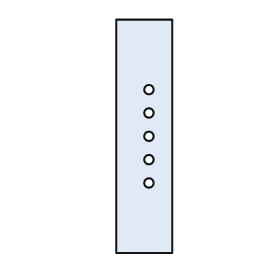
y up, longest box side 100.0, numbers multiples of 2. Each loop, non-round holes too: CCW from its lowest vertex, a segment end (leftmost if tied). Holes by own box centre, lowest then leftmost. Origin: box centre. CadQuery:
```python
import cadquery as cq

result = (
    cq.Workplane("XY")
    .moveTo(-12.0, -50.0)
    .lineTo(12.0, -50.0)
    .lineTo(12.0, 50.0)
    .lineTo(-12.0, 50.0)
    .close()
    .moveTo(2.0, -20.0)
    .circle(2.0)
    .moveTo(2.0, -10.0)
    .circle(2.0)
    .moveTo(2.0, 0.0)
    .circle(2.0)
    .moveTo(2.0, 10.0)
    .circle(2.0)
    .moveTo(2.0, 20.0)
    .circle(2.0)
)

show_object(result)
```